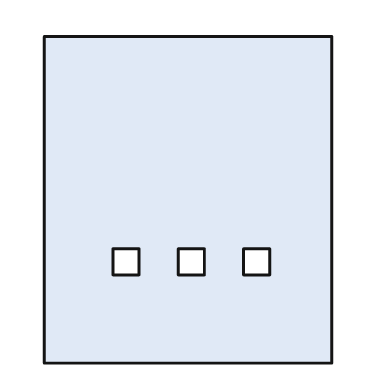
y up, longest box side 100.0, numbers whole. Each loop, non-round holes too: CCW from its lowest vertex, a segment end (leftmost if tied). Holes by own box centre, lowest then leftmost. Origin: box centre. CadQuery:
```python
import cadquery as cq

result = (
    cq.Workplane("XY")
    .moveTo(-44.0, -50.0)
    .lineTo(44.0, -50.0)
    .lineTo(44.0, 50.0)
    .lineTo(-44.0, 50.0)
    .close()
    .moveTo(-23.0, -23.0)
    .lineTo(-15.0, -23.0)
    .lineTo(-15.0, -15.0)
    .lineTo(-23.0, -15.0)
    .close()
    .moveTo(-3.0, -23.0)
    .lineTo(5.0, -23.0)
    .lineTo(5.0, -15.0)
    .lineTo(-3.0, -15.0)
    .close()
    .moveTo(17.0, -23.0)
    .lineTo(25.0, -23.0)
    .lineTo(25.0, -15.0)
    .lineTo(17.0, -15.0)
    .close()
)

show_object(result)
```